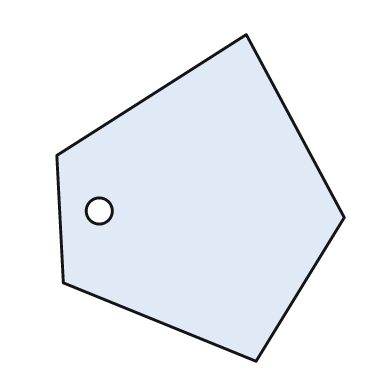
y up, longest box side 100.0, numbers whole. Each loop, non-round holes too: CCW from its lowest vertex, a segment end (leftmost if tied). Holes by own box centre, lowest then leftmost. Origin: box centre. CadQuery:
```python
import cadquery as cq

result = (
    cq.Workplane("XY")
    .moveTo(17.0, -50.0)
    .lineTo(44.0, -6.0)
    .lineTo(14.0, 50.0)
    .lineTo(-44.0, 13.0)
    .lineTo(-42.0, -26.0)
    .close()
    .moveTo(-31.0, -4.0)
    .circle(4.0)
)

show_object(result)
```